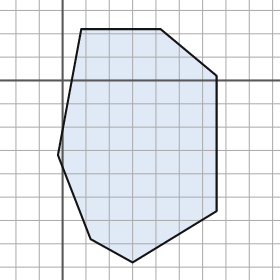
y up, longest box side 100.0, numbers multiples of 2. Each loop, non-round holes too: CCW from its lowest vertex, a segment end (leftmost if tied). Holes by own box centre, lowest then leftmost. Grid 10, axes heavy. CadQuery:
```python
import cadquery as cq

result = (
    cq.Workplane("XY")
    .moveTo(30.0, -78.0)
    .lineTo(66.0, -56.0)
    .lineTo(66.0, 2.0)
    .lineTo(42.0, 22.0)
    .lineTo(8.0, 22.0)
    .lineTo(-2.0, -32.0)
    .lineTo(12.0, -68.0)
    .close()
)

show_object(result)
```